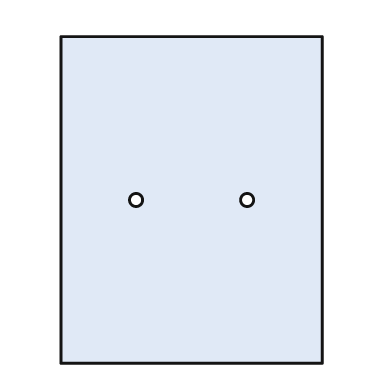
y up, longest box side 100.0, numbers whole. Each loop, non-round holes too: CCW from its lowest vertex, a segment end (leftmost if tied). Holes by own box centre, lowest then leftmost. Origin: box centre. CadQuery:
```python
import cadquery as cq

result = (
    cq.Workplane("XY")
    .moveTo(-40.0, -50.0)
    .lineTo(40.0, -50.0)
    .lineTo(40.0, 50.0)
    .lineTo(-40.0, 50.0)
    .close()
    .moveTo(-17.0, 0.0)
    .circle(2.0)
    .moveTo(17.0, 0.0)
    .circle(2.0)
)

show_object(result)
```